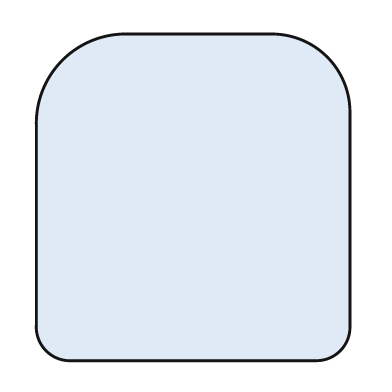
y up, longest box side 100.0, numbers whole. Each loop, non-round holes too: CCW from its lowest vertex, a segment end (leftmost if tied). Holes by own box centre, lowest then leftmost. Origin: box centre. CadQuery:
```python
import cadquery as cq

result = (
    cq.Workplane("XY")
    .moveTo(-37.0, -50.0)
    .lineTo(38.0, -50.0)
    .threePointArc((45.0, -47.0), (48.0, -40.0))
    .lineTo(48.0, 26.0)
    .threePointArc((41.0, 43.0), (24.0, 50.0))
    .lineTo(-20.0, 50.0)
    .threePointArc((-40.0, 42.0), (-48.0, 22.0))
    .lineTo(-48.0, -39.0)
    .threePointArc((-45.0, -47.0), (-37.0, -50.0))
    .close()
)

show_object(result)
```